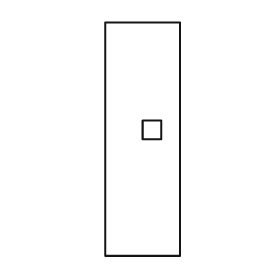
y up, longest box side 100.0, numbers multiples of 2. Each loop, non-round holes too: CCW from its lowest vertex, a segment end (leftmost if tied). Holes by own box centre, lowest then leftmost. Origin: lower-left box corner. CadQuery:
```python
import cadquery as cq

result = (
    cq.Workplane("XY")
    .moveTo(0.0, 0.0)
    .lineTo(32.0, 0.0)
    .lineTo(32.0, 100.0)
    .lineTo(0.0, 100.0)
    .close()
    .moveTo(16.0, 50.0)
    .lineTo(24.0, 50.0)
    .lineTo(24.0, 58.0)
    .lineTo(16.0, 58.0)
    .close()
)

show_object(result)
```